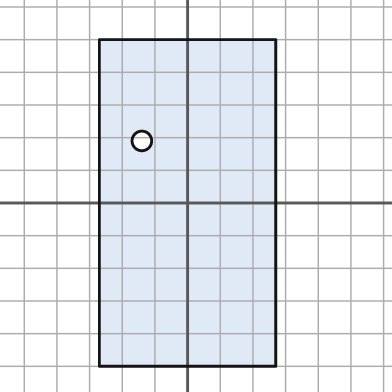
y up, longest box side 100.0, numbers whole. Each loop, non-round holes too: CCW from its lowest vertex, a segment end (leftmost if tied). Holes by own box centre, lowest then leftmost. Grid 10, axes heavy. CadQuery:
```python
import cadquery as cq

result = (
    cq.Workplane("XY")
    .moveTo(-27.0, -50.0)
    .lineTo(27.0, -50.0)
    .lineTo(27.0, 50.0)
    .lineTo(-27.0, 50.0)
    .close()
    .moveTo(-14.0, 19.0)
    .circle(3.0)
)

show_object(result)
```